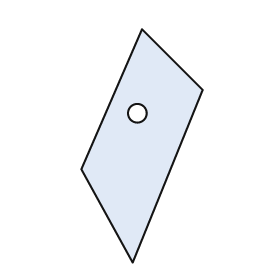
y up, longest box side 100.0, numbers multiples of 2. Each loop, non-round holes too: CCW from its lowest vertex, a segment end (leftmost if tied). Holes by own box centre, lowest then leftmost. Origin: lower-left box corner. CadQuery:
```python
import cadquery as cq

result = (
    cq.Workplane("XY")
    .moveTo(22.0, 0.0)
    .lineTo(52.0, 74.0)
    .lineTo(26.0, 100.0)
    .lineTo(0.0, 40.0)
    .close()
    .moveTo(24.0, 64.0)
    .circle(4.0)
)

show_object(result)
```